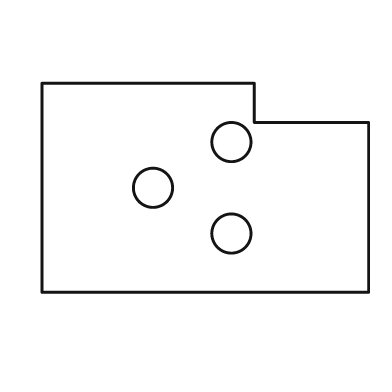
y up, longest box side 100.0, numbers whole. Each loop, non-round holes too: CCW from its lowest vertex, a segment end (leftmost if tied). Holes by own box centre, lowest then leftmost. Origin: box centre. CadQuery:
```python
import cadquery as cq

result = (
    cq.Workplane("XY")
    .moveTo(-50.0, -32.0)
    .lineTo(50.0, -32.0)
    .lineTo(50.0, 20.0)
    .lineTo(15.0, 20.0)
    .lineTo(15.0, 32.0)
    .lineTo(-50.0, 32.0)
    .close()
    .moveTo(8.0, -14.0)
    .circle(6.0)
    .moveTo(-16.0, 0.0)
    .circle(6.0)
    .moveTo(8.0, 14.0)
    .circle(6.0)
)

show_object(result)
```